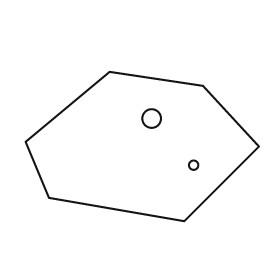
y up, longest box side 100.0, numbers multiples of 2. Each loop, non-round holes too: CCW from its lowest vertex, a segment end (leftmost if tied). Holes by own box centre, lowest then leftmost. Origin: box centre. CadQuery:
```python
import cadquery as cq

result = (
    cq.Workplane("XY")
    .moveTo(18.0, -32.0)
    .lineTo(50.0, 0.0)
    .lineTo(26.0, 26.0)
    .lineTo(-14.0, 32.0)
    .lineTo(-50.0, 2.0)
    .lineTo(-40.0, -22.0)
    .close()
    .moveTo(22.0, -8.0)
    .circle(2.0)
    .moveTo(4.0, 12.0)
    .circle(4.0)
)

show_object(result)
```